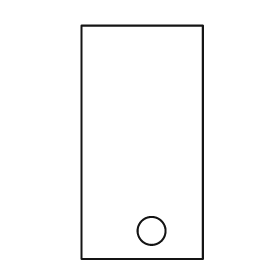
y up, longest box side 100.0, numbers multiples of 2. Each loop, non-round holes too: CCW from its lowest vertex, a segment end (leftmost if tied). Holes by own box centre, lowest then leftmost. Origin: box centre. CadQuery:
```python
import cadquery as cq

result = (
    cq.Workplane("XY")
    .moveTo(-26.0, -50.0)
    .lineTo(26.0, -50.0)
    .lineTo(26.0, 50.0)
    .lineTo(-26.0, 50.0)
    .close()
    .moveTo(4.0, -38.0)
    .circle(6.0)
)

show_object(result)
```